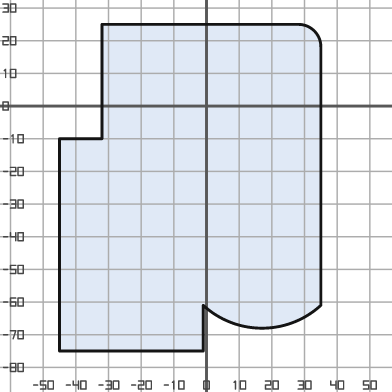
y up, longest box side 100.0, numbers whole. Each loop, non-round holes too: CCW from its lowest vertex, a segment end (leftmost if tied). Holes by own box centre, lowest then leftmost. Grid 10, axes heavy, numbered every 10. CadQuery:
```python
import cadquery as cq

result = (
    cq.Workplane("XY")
    .moveTo(-45.0, -75.0)
    .lineTo(-1.0, -75.0)
    .lineTo(-1.0, -61.0)
    .threePointArc((17.0, -68.0), (35.0, -61.0))
    .lineTo(35.0, 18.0)
    .threePointArc((33.0, 23.0), (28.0, 25.0))
    .lineTo(-32.0, 25.0)
    .lineTo(-32.0, -10.0)
    .lineTo(-45.0, -10.0)
    .close()
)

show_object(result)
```